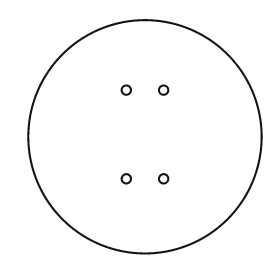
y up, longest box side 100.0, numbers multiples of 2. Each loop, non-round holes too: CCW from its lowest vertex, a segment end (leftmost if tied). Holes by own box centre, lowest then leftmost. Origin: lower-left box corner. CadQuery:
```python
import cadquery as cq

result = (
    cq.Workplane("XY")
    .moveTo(50.0, 50.0)
    .circle(50.0)
    .moveTo(42.0, 32.0)
    .circle(2.0)
    .moveTo(58.0, 32.0)
    .circle(2.0)
    .moveTo(42.0, 70.0)
    .circle(2.0)
    .moveTo(58.0, 70.0)
    .circle(2.0)
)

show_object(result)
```